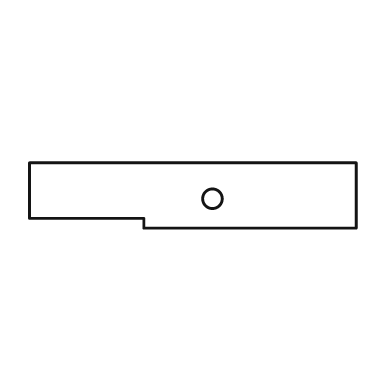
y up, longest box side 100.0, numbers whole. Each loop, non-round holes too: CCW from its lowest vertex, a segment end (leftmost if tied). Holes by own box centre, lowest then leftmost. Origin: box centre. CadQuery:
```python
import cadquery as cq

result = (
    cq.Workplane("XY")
    .moveTo(-15.0, -10.0)
    .lineTo(50.0, -10.0)
    .lineTo(50.0, 10.0)
    .lineTo(-50.0, 10.0)
    .lineTo(-50.0, -7.0)
    .lineTo(-15.0, -7.0)
    .close()
    .moveTo(6.0, -1.0)
    .circle(3.0)
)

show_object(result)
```